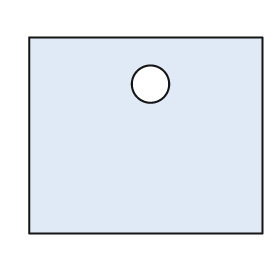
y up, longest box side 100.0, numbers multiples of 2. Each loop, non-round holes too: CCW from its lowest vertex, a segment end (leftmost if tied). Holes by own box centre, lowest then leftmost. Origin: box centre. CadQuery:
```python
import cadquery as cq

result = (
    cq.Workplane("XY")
    .moveTo(-50.0, -42.0)
    .lineTo(50.0, -42.0)
    .lineTo(50.0, 42.0)
    .lineTo(-50.0, 42.0)
    .close()
    .moveTo(2.0, 22.0)
    .circle(8.0)
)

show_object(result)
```